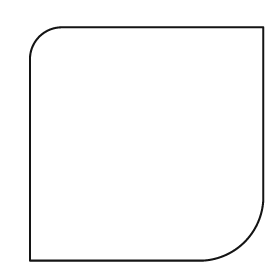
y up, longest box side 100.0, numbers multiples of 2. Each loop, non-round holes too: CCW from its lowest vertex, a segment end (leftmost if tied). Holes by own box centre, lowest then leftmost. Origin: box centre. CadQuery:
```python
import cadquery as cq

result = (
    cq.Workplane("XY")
    .moveTo(-50.0, -50.0)
    .lineTo(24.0, -50.0)
    .threePointArc((42.0, -42.0), (50.0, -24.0))
    .lineTo(50.0, 50.0)
    .lineTo(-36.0, 50.0)
    .threePointArc((-46.0, 46.0), (-50.0, 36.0))
    .close()
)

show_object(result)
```